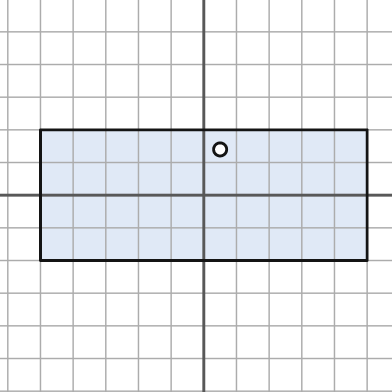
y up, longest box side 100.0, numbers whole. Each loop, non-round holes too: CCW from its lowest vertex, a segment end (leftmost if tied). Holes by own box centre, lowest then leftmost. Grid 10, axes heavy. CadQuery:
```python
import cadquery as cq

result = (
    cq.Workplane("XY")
    .moveTo(-50.0, -20.0)
    .lineTo(50.0, -20.0)
    .lineTo(50.0, 20.0)
    .lineTo(-50.0, 20.0)
    .close()
    .moveTo(5.0, 14.0)
    .circle(2.0)
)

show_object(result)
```